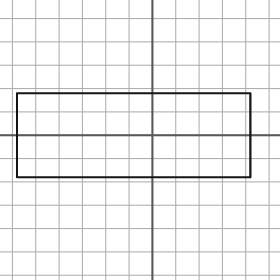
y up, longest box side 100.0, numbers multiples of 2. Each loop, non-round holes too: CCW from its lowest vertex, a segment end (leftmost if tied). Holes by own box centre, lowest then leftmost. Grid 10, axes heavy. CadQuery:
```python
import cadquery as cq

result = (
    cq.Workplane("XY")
    .moveTo(-58.0, -18.0)
    .lineTo(42.0, -18.0)
    .lineTo(42.0, 18.0)
    .lineTo(-58.0, 18.0)
    .close()
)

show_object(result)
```